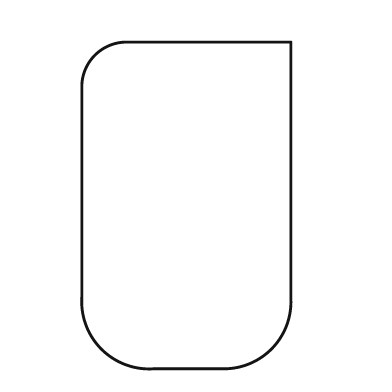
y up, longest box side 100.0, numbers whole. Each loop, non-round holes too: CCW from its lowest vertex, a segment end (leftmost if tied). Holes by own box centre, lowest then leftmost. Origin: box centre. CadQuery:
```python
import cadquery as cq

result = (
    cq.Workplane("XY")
    .moveTo(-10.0, -50.0)
    .lineTo(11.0, -50.0)
    .threePointArc((26.0, -44.0), (32.0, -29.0))
    .lineTo(32.0, 50.0)
    .lineTo(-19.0, 50.0)
    .threePointArc((-28.0, 46.0), (-32.0, 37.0))
    .lineTo(-32.0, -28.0)
    .threePointArc((-26.0, -44.0), (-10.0, -50.0))
    .close()
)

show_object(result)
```